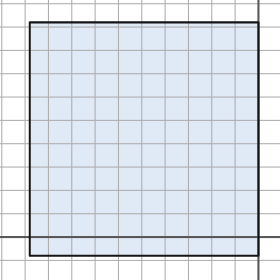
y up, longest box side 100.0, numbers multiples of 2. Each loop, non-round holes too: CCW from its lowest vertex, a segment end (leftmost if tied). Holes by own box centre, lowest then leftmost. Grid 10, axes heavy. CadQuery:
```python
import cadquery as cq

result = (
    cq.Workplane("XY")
    .moveTo(-98.0, -8.0)
    .lineTo(0.0, -8.0)
    .lineTo(0.0, 92.0)
    .lineTo(-98.0, 92.0)
    .close()
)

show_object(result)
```